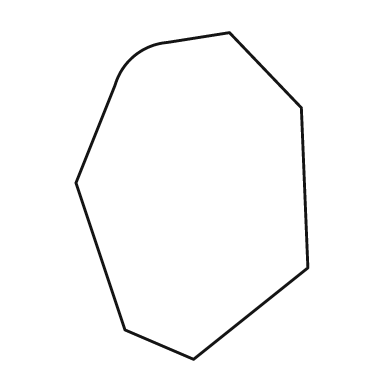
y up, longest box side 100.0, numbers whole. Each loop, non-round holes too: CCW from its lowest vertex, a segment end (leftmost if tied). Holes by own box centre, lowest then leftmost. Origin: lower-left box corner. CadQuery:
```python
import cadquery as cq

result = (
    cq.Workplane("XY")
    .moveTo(36.0, 0.0)
    .lineTo(71.0, 28.0)
    .lineTo(69.0, 77.0)
    .lineTo(47.0, 100.0)
    .lineTo(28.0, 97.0)
    .threePointArc((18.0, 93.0), (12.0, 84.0))
    .lineTo(0.0, 54.0)
    .lineTo(15.0, 9.0)
    .close()
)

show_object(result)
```